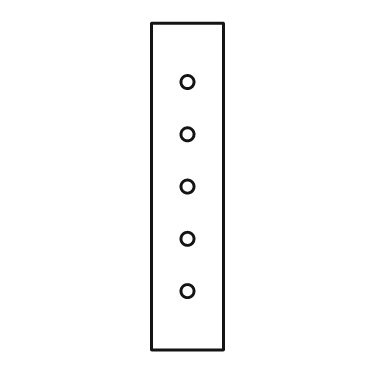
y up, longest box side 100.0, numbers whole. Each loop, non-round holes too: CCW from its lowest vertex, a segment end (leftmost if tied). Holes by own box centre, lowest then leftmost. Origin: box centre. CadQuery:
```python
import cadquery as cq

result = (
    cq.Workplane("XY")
    .moveTo(-11.0, -50.0)
    .lineTo(11.0, -50.0)
    .lineTo(11.0, 50.0)
    .lineTo(-11.0, 50.0)
    .close()
    .moveTo(0.0, -32.0)
    .circle(2.0)
    .moveTo(0.0, -16.0)
    .circle(2.0)
    .moveTo(0.0, 0.0)
    .circle(2.0)
    .moveTo(0.0, 16.0)
    .circle(2.0)
    .moveTo(0.0, 32.0)
    .circle(2.0)
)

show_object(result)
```